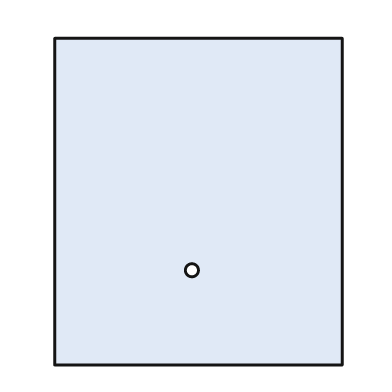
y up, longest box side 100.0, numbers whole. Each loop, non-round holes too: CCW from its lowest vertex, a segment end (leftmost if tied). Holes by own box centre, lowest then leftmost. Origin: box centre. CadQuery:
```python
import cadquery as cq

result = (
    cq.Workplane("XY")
    .moveTo(-44.0, -50.0)
    .lineTo(44.0, -50.0)
    .lineTo(44.0, 50.0)
    .lineTo(-44.0, 50.0)
    .close()
    .moveTo(-2.0, -21.0)
    .circle(2.0)
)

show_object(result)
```